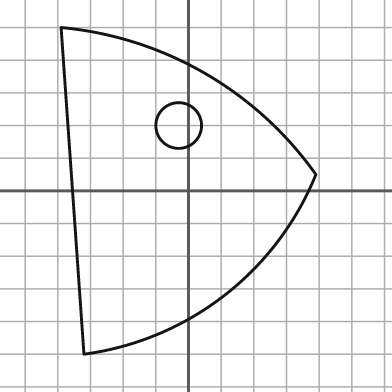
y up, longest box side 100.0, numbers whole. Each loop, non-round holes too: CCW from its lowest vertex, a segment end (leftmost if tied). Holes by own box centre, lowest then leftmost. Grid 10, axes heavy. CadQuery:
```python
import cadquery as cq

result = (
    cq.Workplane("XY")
    .moveTo(-32.0, -50.0)
    .threePointArc((11.0, -32.0), (39.0, 5.0))
    .threePointArc((5.0, 36.0), (-39.0, 50.0))
    .close()
    .moveTo(-3.0, 20.0)
    .circle(7.0)
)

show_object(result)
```